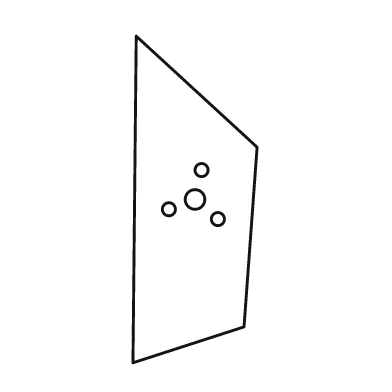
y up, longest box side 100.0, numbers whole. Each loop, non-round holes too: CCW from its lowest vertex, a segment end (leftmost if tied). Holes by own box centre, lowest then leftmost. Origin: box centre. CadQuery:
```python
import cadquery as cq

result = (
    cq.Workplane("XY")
    .moveTo(-19.0, -50.0)
    .lineTo(15.0, -39.0)
    .lineTo(19.0, 16.0)
    .lineTo(-18.0, 50.0)
    .close()
    .moveTo(7.0, -6.0)
    .circle(2.0)
    .moveTo(-8.0, -3.0)
    .circle(2.0)
    .moveTo(0.0, 0.0)
    .circle(3.0)
    .moveTo(2.0, 9.0)
    .circle(2.0)
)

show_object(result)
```